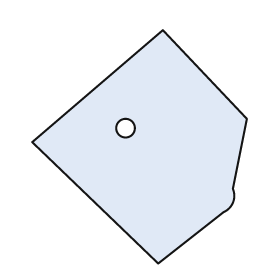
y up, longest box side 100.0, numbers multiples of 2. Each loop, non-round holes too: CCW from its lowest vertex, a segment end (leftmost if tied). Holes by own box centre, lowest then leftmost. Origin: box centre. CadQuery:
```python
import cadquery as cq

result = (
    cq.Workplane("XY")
    .moveTo(8.0, -50.0)
    .lineTo(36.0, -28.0)
    .threePointArc((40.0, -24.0), (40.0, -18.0))
    .lineTo(46.0, 12.0)
    .lineTo(10.0, 50.0)
    .lineTo(-46.0, 2.0)
    .close()
    .moveTo(-6.0, 8.0)
    .circle(4.0)
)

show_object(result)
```